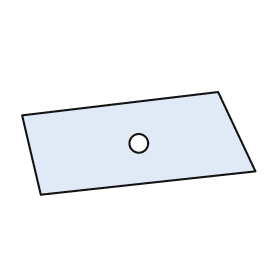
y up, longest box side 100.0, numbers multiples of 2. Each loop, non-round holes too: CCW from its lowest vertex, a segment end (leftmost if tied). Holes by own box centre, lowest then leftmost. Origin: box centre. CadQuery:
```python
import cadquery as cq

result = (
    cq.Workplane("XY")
    .moveTo(-42.0, -22.0)
    .lineTo(50.0, -12.0)
    .lineTo(34.0, 22.0)
    .lineTo(-50.0, 12.0)
    .close()
    .moveTo(0.0, 0.0)
    .circle(4.0)
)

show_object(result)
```